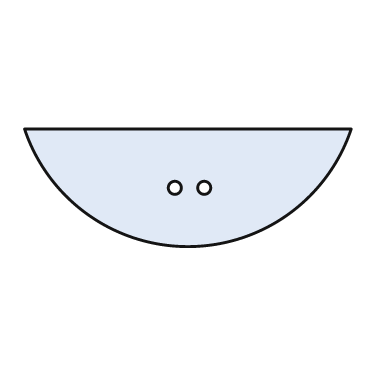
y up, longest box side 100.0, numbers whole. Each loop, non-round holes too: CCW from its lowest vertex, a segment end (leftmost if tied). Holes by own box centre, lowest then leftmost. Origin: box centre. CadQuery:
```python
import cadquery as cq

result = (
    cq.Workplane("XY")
    .moveTo(-50.0, 18.0)
    .threePointArc((0.0, -18.0), (50.0, 18.0))
    .close()
    .moveTo(-4.0, 0.0)
    .circle(2.0)
    .moveTo(5.0, 0.0)
    .circle(2.0)
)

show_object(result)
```